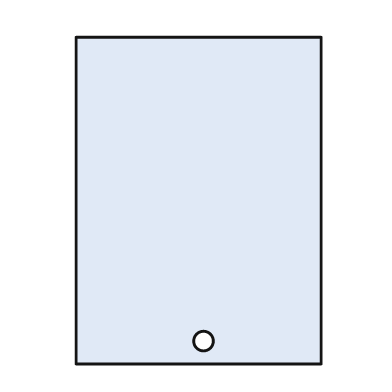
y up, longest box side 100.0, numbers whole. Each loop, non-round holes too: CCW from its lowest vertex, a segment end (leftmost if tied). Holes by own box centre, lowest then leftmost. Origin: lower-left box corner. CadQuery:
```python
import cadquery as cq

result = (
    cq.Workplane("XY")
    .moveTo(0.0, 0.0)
    .lineTo(75.0, 0.0)
    .lineTo(75.0, 100.0)
    .lineTo(0.0, 100.0)
    .close()
    .moveTo(39.0, 7.0)
    .circle(3.0)
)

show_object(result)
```